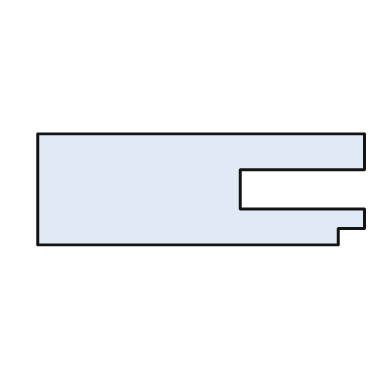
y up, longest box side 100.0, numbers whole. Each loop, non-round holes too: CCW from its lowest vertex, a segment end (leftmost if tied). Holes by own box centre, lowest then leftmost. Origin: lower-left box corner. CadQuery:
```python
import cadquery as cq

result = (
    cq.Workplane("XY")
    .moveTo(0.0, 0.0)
    .lineTo(92.0, 0.0)
    .lineTo(92.0, 5.0)
    .lineTo(100.0, 5.0)
    .lineTo(100.0, 11.0)
    .lineTo(62.0, 11.0)
    .lineTo(62.0, 23.0)
    .lineTo(100.0, 23.0)
    .lineTo(100.0, 34.0)
    .lineTo(0.0, 34.0)
    .close()
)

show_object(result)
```